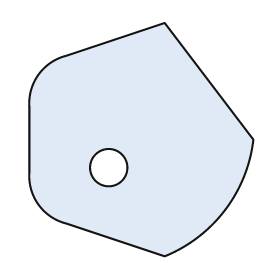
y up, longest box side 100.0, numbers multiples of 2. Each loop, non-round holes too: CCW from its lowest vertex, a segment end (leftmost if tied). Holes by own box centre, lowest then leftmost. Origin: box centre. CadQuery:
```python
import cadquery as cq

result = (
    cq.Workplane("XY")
    .moveTo(10.0, -50.0)
    .threePointArc((36.0, -30.0), (48.0, 0.0))
    .lineTo(10.0, 50.0)
    .lineTo(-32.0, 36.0)
    .threePointArc((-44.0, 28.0), (-48.0, 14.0))
    .lineTo(-48.0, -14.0)
    .threePointArc((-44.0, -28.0), (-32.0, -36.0))
    .close()
    .moveTo(-14.0, -12.0)
    .circle(8.0)
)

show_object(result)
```